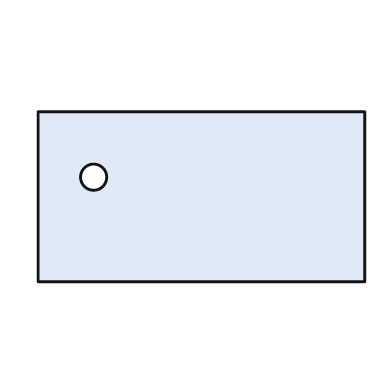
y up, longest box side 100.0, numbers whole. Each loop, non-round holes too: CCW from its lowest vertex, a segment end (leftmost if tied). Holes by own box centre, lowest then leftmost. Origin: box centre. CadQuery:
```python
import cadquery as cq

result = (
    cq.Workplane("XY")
    .moveTo(-50.0, -26.0)
    .lineTo(50.0, -26.0)
    .lineTo(50.0, 26.0)
    .lineTo(-50.0, 26.0)
    .close()
    .moveTo(-33.0, 6.0)
    .circle(4.0)
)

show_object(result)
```